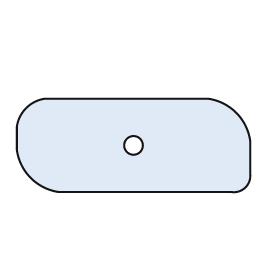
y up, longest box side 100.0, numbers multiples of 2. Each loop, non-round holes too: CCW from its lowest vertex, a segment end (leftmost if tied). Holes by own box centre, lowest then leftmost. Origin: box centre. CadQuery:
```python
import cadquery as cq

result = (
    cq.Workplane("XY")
    .moveTo(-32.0, -20.0)
    .lineTo(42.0, -20.0)
    .threePointArc((48.0, -18.0), (50.0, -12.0))
    .lineTo(50.0, 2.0)
    .threePointArc((44.0, 14.0), (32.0, 20.0))
    .lineTo(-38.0, 20.0)
    .threePointArc((-46.0, 16.0), (-50.0, 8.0))
    .lineTo(-50.0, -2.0)
    .threePointArc((-44.0, -14.0), (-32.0, -20.0))
    .close()
    .moveTo(0.0, 0.0)
    .circle(4.0)
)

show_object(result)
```